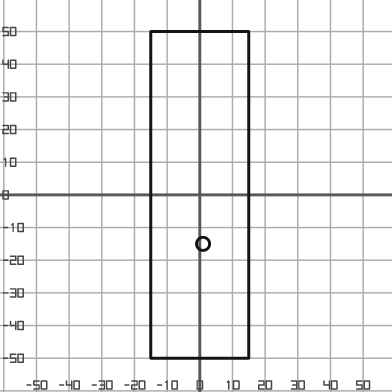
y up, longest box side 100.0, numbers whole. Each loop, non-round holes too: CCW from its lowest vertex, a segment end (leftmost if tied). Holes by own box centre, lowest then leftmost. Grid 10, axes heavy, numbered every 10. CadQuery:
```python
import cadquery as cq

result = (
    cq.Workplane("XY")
    .moveTo(-15.0, -50.0)
    .lineTo(15.0, -50.0)
    .lineTo(15.0, 50.0)
    .lineTo(-15.0, 50.0)
    .close()
    .moveTo(1.0, -15.0)
    .circle(2.0)
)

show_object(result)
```